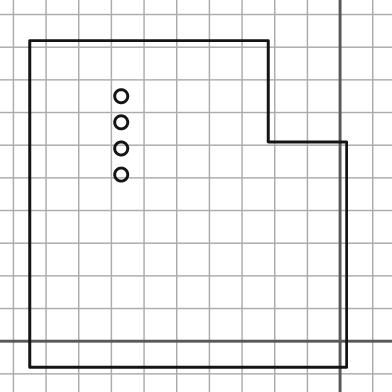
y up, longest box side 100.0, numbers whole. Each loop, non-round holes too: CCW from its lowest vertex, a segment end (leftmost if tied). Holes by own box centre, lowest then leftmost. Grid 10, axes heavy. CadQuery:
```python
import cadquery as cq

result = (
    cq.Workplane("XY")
    .moveTo(-95.0, -8.0)
    .lineTo(2.0, -8.0)
    .lineTo(2.0, 61.0)
    .lineTo(-22.0, 61.0)
    .lineTo(-22.0, 92.0)
    .lineTo(-95.0, 92.0)
    .close()
    .moveTo(-67.0, 51.0)
    .circle(2.0)
    .moveTo(-67.0, 59.0)
    .circle(2.0)
    .moveTo(-67.0, 67.0)
    .circle(2.0)
    .moveTo(-67.0, 75.0)
    .circle(2.0)
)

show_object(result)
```